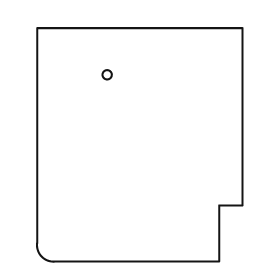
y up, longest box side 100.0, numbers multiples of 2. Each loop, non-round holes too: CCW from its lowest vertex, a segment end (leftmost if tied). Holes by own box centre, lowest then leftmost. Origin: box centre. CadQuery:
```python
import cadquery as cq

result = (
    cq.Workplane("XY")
    .moveTo(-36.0, -50.0)
    .lineTo(34.0, -50.0)
    .lineTo(34.0, -26.0)
    .lineTo(44.0, -26.0)
    .lineTo(44.0, 50.0)
    .lineTo(-44.0, 50.0)
    .lineTo(-44.0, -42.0)
    .threePointArc((-42.0, -48.0), (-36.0, -50.0))
    .close()
    .moveTo(-14.0, 30.0)
    .circle(2.0)
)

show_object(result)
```